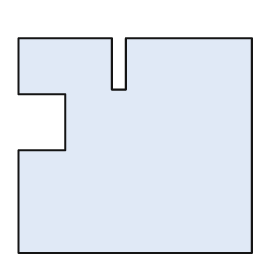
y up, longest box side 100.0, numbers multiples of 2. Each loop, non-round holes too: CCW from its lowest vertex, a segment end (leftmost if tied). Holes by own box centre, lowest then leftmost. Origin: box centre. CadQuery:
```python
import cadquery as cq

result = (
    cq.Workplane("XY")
    .moveTo(-50.0, -46.0)
    .lineTo(50.0, -46.0)
    .lineTo(50.0, 46.0)
    .lineTo(-4.0, 46.0)
    .lineTo(-4.0, 24.0)
    .lineTo(-10.0, 24.0)
    .lineTo(-10.0, 46.0)
    .lineTo(-50.0, 46.0)
    .lineTo(-50.0, 22.0)
    .lineTo(-30.0, 22.0)
    .lineTo(-30.0, -2.0)
    .lineTo(-50.0, -2.0)
    .close()
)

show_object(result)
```